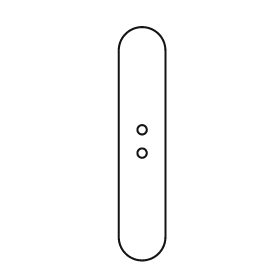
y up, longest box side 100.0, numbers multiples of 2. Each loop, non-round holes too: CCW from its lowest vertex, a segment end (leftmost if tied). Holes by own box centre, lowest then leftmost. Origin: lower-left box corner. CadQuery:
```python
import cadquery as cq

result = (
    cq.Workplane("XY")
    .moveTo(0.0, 10.0)
    .threePointArc((10.0, 0.0), (20.0, 10.0))
    .lineTo(20.0, 90.0)
    .threePointArc((10.0, 100.0), (0.0, 90.0))
    .close()
    .moveTo(10.0, 46.0)
    .circle(2.0)
    .moveTo(10.0, 56.0)
    .circle(2.0)
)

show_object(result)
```